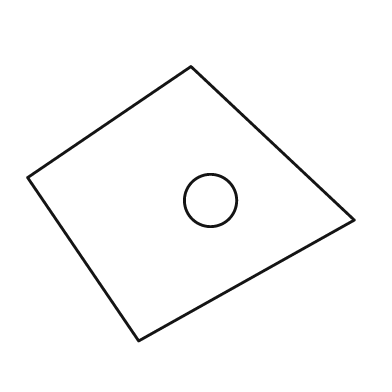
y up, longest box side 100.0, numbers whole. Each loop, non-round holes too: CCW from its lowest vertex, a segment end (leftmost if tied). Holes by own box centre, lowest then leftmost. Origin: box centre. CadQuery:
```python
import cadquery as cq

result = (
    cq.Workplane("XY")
    .moveTo(-16.0, -42.0)
    .lineTo(50.0, -5.0)
    .lineTo(0.0, 42.0)
    .lineTo(-50.0, 8.0)
    .close()
    .moveTo(6.0, 1.0)
    .circle(8.0)
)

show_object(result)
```